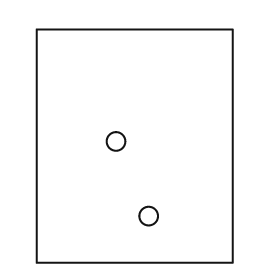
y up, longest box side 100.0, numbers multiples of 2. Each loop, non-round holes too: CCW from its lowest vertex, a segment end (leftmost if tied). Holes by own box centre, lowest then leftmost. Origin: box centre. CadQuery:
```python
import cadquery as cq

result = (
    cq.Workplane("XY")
    .moveTo(-42.0, -50.0)
    .lineTo(42.0, -50.0)
    .lineTo(42.0, 50.0)
    .lineTo(-42.0, 50.0)
    .close()
    .moveTo(6.0, -30.0)
    .circle(4.0)
    .moveTo(-8.0, 2.0)
    .circle(4.0)
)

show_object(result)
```